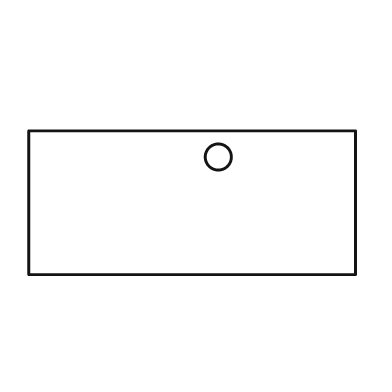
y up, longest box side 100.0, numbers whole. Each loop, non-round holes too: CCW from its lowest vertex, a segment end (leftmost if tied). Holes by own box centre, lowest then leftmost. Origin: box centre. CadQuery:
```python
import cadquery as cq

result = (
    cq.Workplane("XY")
    .moveTo(-50.0, -22.0)
    .lineTo(50.0, -22.0)
    .lineTo(50.0, 22.0)
    .lineTo(-50.0, 22.0)
    .close()
    .moveTo(8.0, 14.0)
    .circle(4.0)
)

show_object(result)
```